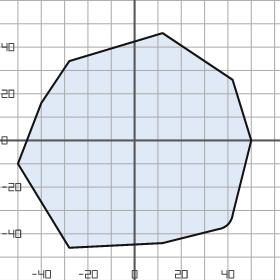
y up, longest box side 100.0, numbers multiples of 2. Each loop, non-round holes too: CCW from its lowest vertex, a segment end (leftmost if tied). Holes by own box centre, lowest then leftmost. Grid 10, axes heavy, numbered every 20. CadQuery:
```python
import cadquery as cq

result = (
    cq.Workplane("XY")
    .moveTo(-28.0, -46.0)
    .lineTo(12.0, -44.0)
    .lineTo(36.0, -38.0)
    .threePointArc((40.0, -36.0), (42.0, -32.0))
    .lineTo(50.0, 0.0)
    .lineTo(42.0, 26.0)
    .lineTo(12.0, 46.0)
    .lineTo(-28.0, 34.0)
    .lineTo(-40.0, 16.0)
    .lineTo(-50.0, -10.0)
    .close()
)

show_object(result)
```